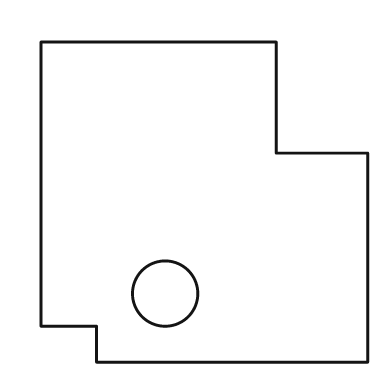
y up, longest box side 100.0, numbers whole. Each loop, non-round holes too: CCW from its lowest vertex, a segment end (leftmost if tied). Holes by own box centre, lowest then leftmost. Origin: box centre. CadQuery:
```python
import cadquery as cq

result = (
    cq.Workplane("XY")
    .moveTo(-33.0, -49.0)
    .lineTo(50.0, -49.0)
    .lineTo(50.0, 15.0)
    .lineTo(22.0, 15.0)
    .lineTo(22.0, 49.0)
    .lineTo(-50.0, 49.0)
    .lineTo(-50.0, -38.0)
    .lineTo(-33.0, -38.0)
    .close()
    .moveTo(-12.0, -28.0)
    .circle(10.0)
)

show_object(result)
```